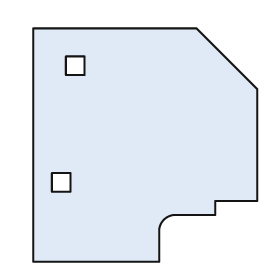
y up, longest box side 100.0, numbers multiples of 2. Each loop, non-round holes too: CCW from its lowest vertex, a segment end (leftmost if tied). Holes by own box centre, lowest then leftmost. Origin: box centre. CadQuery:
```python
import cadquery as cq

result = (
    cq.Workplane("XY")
    .moveTo(-48.0, -50.0)
    .lineTo(6.0, -50.0)
    .lineTo(6.0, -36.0)
    .threePointArc((8.0, -32.0), (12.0, -30.0))
    .lineTo(30.0, -30.0)
    .lineTo(30.0, -24.0)
    .lineTo(48.0, -24.0)
    .lineTo(48.0, 24.0)
    .lineTo(22.0, 50.0)
    .lineTo(-48.0, 50.0)
    .close()
    .moveTo(-40.0, -20.0)
    .lineTo(-32.0, -20.0)
    .lineTo(-32.0, -12.0)
    .lineTo(-40.0, -12.0)
    .close()
    .moveTo(-34.0, 30.0)
    .lineTo(-26.0, 30.0)
    .lineTo(-26.0, 38.0)
    .lineTo(-34.0, 38.0)
    .close()
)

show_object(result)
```